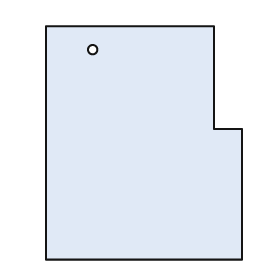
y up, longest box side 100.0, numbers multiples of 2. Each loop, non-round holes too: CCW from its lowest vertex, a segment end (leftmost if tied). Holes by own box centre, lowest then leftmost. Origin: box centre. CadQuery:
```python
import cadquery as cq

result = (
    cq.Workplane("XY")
    .moveTo(-42.0, -50.0)
    .lineTo(42.0, -50.0)
    .lineTo(42.0, 6.0)
    .lineTo(30.0, 6.0)
    .lineTo(30.0, 50.0)
    .lineTo(-42.0, 50.0)
    .close()
    .moveTo(-22.0, 40.0)
    .circle(2.0)
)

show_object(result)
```